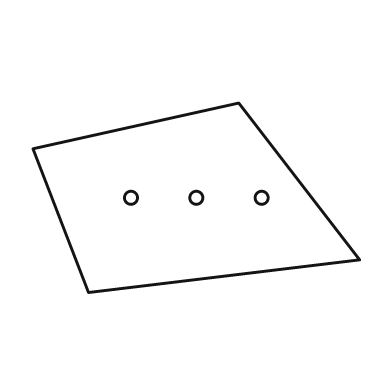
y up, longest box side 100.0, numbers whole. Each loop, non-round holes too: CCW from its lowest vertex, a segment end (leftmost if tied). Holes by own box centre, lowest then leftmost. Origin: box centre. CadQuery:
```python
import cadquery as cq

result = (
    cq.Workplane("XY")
    .moveTo(-33.0, -29.0)
    .lineTo(50.0, -19.0)
    .lineTo(13.0, 29.0)
    .lineTo(-50.0, 15.0)
    .close()
    .moveTo(-20.0, 0.0)
    .circle(2.0)
    .moveTo(0.0, 0.0)
    .circle(2.0)
    .moveTo(20.0, 0.0)
    .circle(2.0)
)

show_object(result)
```